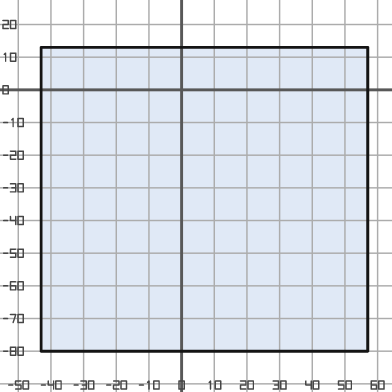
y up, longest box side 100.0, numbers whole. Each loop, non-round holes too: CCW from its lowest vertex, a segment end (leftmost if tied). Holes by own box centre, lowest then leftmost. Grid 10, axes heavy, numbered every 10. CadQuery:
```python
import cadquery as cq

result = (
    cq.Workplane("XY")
    .moveTo(-43.0, -80.0)
    .lineTo(57.0, -80.0)
    .lineTo(57.0, 13.0)
    .lineTo(-43.0, 13.0)
    .close()
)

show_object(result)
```